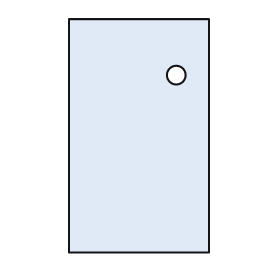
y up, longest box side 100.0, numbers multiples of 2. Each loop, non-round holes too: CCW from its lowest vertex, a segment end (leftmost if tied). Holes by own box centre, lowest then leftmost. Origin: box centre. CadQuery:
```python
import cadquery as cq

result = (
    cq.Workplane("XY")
    .moveTo(-30.0, -50.0)
    .lineTo(30.0, -50.0)
    .lineTo(30.0, 50.0)
    .lineTo(-30.0, 50.0)
    .close()
    .moveTo(16.0, 26.0)
    .circle(4.0)
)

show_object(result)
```